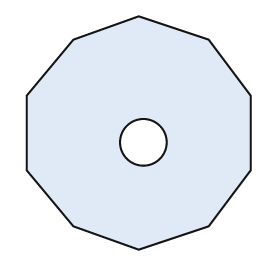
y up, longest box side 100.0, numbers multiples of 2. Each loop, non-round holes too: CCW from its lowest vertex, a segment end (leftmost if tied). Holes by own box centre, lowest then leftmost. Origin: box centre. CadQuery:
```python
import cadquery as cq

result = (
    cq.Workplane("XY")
    .moveTo(0.0, -50.0)
    .lineTo(30.0, -40.0)
    .lineTo(48.0, -16.0)
    .lineTo(48.0, 16.0)
    .lineTo(30.0, 40.0)
    .lineTo(0.0, 50.0)
    .lineTo(-28.0, 40.0)
    .lineTo(-48.0, 16.0)
    .lineTo(-48.0, -16.0)
    .lineTo(-28.0, -40.0)
    .close()
    .moveTo(2.0, -4.0)
    .circle(10.0)
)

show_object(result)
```